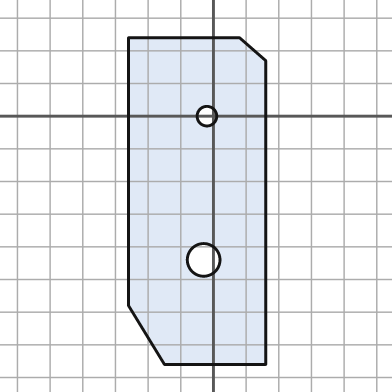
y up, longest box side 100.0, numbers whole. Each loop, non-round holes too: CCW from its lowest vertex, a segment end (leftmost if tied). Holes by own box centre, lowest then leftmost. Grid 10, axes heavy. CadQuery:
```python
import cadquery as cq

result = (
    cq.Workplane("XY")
    .moveTo(-15.0, -76.0)
    .lineTo(16.0, -76.0)
    .lineTo(16.0, 17.0)
    .lineTo(8.0, 24.0)
    .lineTo(-26.0, 24.0)
    .lineTo(-26.0, -58.0)
    .close()
    .moveTo(-3.0, -44.0)
    .circle(5.0)
    .moveTo(-2.0, 0.0)
    .circle(3.0)
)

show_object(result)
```